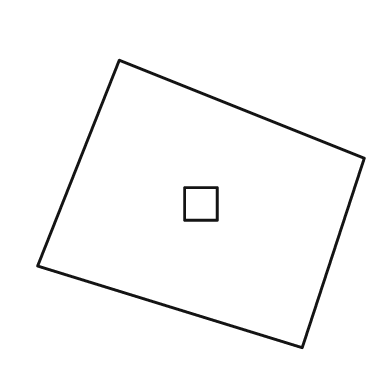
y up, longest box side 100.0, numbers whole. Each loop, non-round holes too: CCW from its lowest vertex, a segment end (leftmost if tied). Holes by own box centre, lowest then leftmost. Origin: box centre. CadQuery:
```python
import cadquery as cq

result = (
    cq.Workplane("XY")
    .moveTo(31.0, -44.0)
    .lineTo(50.0, 14.0)
    .lineTo(-25.0, 44.0)
    .lineTo(-50.0, -19.0)
    .close()
    .moveTo(-5.0, -5.0)
    .lineTo(5.0, -5.0)
    .lineTo(5.0, 5.0)
    .lineTo(-5.0, 5.0)
    .close()
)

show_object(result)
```